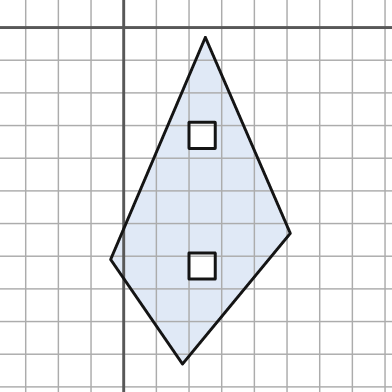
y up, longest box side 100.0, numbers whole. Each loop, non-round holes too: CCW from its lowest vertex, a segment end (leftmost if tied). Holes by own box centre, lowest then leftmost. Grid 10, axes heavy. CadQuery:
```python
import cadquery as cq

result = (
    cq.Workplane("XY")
    .moveTo(18.0, -103.0)
    .lineTo(51.0, -63.0)
    .lineTo(25.0, -3.0)
    .lineTo(-4.0, -71.0)
    .close()
    .moveTo(20.0, -77.0)
    .lineTo(28.0, -77.0)
    .lineTo(28.0, -69.0)
    .lineTo(20.0, -69.0)
    .close()
    .moveTo(20.0, -37.0)
    .lineTo(28.0, -37.0)
    .lineTo(28.0, -29.0)
    .lineTo(20.0, -29.0)
    .close()
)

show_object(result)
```